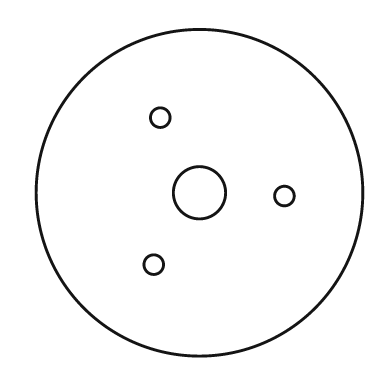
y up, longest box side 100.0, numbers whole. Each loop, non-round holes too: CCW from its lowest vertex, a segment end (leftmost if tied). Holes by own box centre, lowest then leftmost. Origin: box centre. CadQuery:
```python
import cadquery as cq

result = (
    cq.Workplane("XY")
    .moveTo(0.0, 0.0)
    .circle(50.0)
    .moveTo(-14.0, -22.0)
    .circle(3.0)
    .moveTo(26.0, -1.0)
    .circle(3.0)
    .moveTo(0.0, 0.0)
    .circle(8.0)
    .moveTo(-12.0, 23.0)
    .circle(3.0)
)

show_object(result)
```